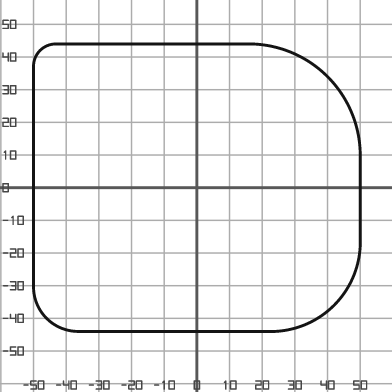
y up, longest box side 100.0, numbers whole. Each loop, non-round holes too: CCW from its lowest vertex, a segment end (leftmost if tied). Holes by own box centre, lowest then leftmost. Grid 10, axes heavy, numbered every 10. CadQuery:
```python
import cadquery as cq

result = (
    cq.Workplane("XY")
    .moveTo(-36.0, -44.0)
    .lineTo(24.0, -44.0)
    .threePointArc((42.0, -36.0), (50.0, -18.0))
    .lineTo(50.0, 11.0)
    .threePointArc((40.0, 34.0), (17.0, 44.0))
    .lineTo(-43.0, 44.0)
    .threePointArc((-48.0, 42.0), (-50.0, 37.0))
    .lineTo(-50.0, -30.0)
    .threePointArc((-46.0, -40.0), (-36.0, -44.0))
    .close()
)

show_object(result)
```